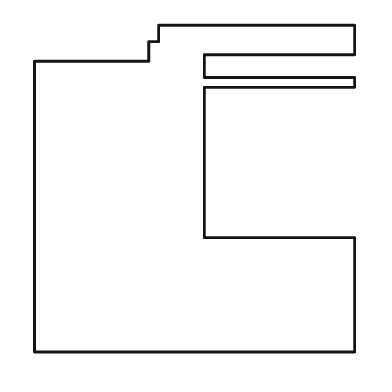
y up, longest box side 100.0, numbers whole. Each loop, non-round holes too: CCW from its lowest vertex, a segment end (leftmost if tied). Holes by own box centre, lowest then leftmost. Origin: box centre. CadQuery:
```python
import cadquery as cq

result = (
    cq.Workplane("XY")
    .moveTo(-49.0, -50.0)
    .lineTo(49.0, -50.0)
    .lineTo(49.0, -15.0)
    .lineTo(3.0, -15.0)
    .lineTo(3.0, 31.0)
    .lineTo(49.0, 31.0)
    .lineTo(49.0, 34.0)
    .lineTo(3.0, 34.0)
    .lineTo(3.0, 41.0)
    .lineTo(49.0, 41.0)
    .lineTo(49.0, 50.0)
    .lineTo(-11.0, 50.0)
    .lineTo(-11.0, 45.0)
    .lineTo(-14.0, 45.0)
    .lineTo(-14.0, 39.0)
    .lineTo(-49.0, 39.0)
    .close()
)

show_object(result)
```